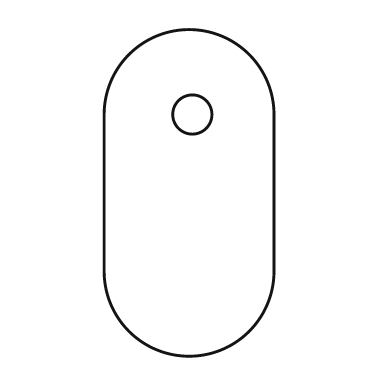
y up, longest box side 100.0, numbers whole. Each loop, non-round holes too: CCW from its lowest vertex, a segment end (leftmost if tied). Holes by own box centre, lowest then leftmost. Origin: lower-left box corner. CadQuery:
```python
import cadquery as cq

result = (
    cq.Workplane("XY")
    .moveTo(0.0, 26.0)
    .threePointArc((26.0, 0.0), (52.0, 26.0))
    .lineTo(52.0, 74.0)
    .threePointArc((26.0, 100.0), (0.0, 74.0))
    .close()
    .moveTo(27.0, 74.0)
    .circle(6.0)
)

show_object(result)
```